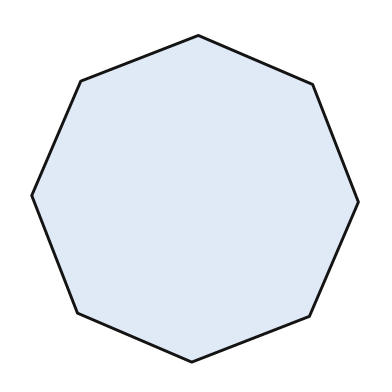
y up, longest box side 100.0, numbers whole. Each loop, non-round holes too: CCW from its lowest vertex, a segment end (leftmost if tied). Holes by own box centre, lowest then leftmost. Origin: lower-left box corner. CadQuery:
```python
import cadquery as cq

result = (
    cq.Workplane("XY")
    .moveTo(49.0, 0.0)
    .lineTo(85.0, 14.0)
    .lineTo(100.0, 49.0)
    .lineTo(86.0, 85.0)
    .lineTo(51.0, 100.0)
    .lineTo(15.0, 86.0)
    .lineTo(0.0, 51.0)
    .lineTo(14.0, 15.0)
    .close()
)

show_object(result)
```